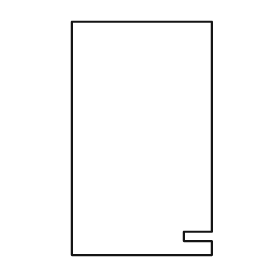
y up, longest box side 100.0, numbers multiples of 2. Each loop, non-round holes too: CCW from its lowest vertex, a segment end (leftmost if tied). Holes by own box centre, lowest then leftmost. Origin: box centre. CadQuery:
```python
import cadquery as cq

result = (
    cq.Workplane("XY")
    .moveTo(-30.0, -50.0)
    .lineTo(30.0, -50.0)
    .lineTo(30.0, -44.0)
    .lineTo(18.0, -44.0)
    .lineTo(18.0, -40.0)
    .lineTo(30.0, -40.0)
    .lineTo(30.0, 50.0)
    .lineTo(-30.0, 50.0)
    .close()
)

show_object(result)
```